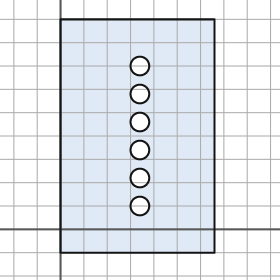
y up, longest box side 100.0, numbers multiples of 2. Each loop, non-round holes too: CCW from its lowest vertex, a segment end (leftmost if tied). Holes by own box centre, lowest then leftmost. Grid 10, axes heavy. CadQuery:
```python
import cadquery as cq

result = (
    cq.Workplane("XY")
    .moveTo(0.0, -10.0)
    .lineTo(66.0, -10.0)
    .lineTo(66.0, 90.0)
    .lineTo(0.0, 90.0)
    .close()
    .moveTo(34.0, 10.0)
    .circle(4.0)
    .moveTo(34.0, 22.0)
    .circle(4.0)
    .moveTo(34.0, 34.0)
    .circle(4.0)
    .moveTo(34.0, 46.0)
    .circle(4.0)
    .moveTo(34.0, 58.0)
    .circle(4.0)
    .moveTo(34.0, 70.0)
    .circle(4.0)
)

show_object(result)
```